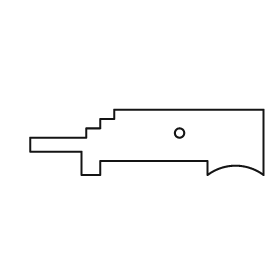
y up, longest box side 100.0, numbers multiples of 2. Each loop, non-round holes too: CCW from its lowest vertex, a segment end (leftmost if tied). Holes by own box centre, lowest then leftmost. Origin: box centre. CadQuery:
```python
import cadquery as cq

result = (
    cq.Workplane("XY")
    .moveTo(-28.0, -14.0)
    .lineTo(-20.0, -14.0)
    .lineTo(-20.0, -8.0)
    .lineTo(26.0, -8.0)
    .lineTo(26.0, -14.0)
    .threePointArc((38.0, -10.0), (50.0, -14.0))
    .lineTo(50.0, 14.0)
    .lineTo(-14.0, 14.0)
    .lineTo(-14.0, 10.0)
    .lineTo(-20.0, 10.0)
    .lineTo(-20.0, 6.0)
    .lineTo(-26.0, 6.0)
    .lineTo(-26.0, 2.0)
    .lineTo(-50.0, 2.0)
    .lineTo(-50.0, -4.0)
    .lineTo(-28.0, -4.0)
    .close()
    .moveTo(14.0, 4.0)
    .circle(2.0)
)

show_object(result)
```